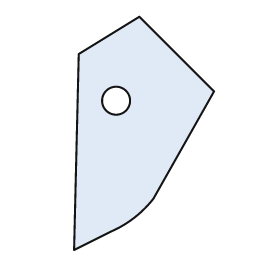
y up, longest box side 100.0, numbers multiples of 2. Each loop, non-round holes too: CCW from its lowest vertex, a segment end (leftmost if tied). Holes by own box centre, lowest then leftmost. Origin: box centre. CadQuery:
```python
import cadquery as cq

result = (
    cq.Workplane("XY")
    .moveTo(-30.0, -50.0)
    .lineTo(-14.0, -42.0)
    .threePointArc((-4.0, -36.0), (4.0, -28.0))
    .lineTo(30.0, 18.0)
    .lineTo(-2.0, 50.0)
    .lineTo(-28.0, 34.0)
    .close()
    .moveTo(-12.0, 14.0)
    .circle(6.0)
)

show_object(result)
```